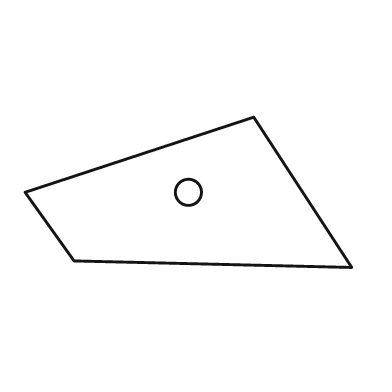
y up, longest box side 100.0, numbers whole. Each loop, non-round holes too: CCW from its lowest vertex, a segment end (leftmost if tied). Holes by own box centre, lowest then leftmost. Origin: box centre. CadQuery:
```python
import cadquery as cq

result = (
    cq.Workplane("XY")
    .moveTo(50.0, -23.0)
    .lineTo(20.0, 23.0)
    .lineTo(-50.0, 0.0)
    .lineTo(-35.0, -21.0)
    .close()
    .moveTo(0.0, 0.0)
    .circle(4.0)
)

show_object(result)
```